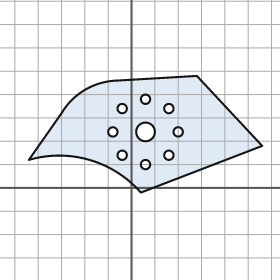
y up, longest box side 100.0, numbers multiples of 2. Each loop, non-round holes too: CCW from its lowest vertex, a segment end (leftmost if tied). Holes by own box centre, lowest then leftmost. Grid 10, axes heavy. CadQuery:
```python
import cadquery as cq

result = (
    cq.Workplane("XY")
    .moveTo(4.0, -2.0)
    .lineTo(56.0, 18.0)
    .lineTo(28.0, 48.0)
    .lineTo(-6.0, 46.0)
    .threePointArc((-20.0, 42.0), (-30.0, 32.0))
    .lineTo(-44.0, 12.0)
    .threePointArc((-18.0, 12.0), (4.0, -2.0))
    .close()
    .moveTo(6.0, 10.0)
    .circle(2.0)
    .moveTo(-4.0, 14.0)
    .circle(2.0)
    .moveTo(16.0, 14.0)
    .circle(2.0)
    .moveTo(-8.0, 24.0)
    .circle(2.0)
    .moveTo(6.0, 24.0)
    .circle(4.0)
    .moveTo(20.0, 24.0)
    .circle(2.0)
    .moveTo(-4.0, 34.0)
    .circle(2.0)
    .moveTo(16.0, 34.0)
    .circle(2.0)
    .moveTo(6.0, 38.0)
    .circle(2.0)
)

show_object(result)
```